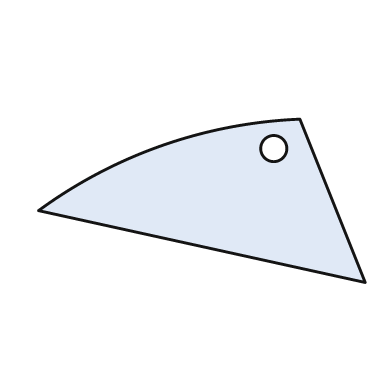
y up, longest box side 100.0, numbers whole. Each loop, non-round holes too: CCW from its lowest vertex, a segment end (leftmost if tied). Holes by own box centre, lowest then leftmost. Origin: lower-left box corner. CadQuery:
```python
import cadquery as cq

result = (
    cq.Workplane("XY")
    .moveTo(100.0, 0.0)
    .lineTo(80.0, 50.0)
    .threePointArc((38.0, 42.0), (0.0, 22.0))
    .close()
    .moveTo(72.0, 41.0)
    .circle(4.0)
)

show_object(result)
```